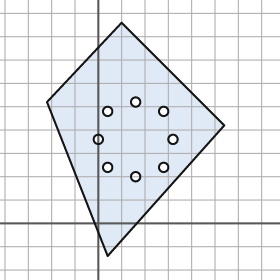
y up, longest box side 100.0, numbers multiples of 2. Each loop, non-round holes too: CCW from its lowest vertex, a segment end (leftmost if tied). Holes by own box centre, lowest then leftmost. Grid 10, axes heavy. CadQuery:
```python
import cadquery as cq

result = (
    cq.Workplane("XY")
    .moveTo(4.0, -14.0)
    .lineTo(54.0, 42.0)
    .lineTo(10.0, 86.0)
    .lineTo(-22.0, 52.0)
    .close()
    .moveTo(16.0, 20.0)
    .circle(2.0)
    .moveTo(4.0, 24.0)
    .circle(2.0)
    .moveTo(28.0, 24.0)
    .circle(2.0)
    .moveTo(0.0, 36.0)
    .circle(2.0)
    .moveTo(32.0, 36.0)
    .circle(2.0)
    .moveTo(4.0, 48.0)
    .circle(2.0)
    .moveTo(28.0, 48.0)
    .circle(2.0)
    .moveTo(16.0, 52.0)
    .circle(2.0)
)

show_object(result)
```